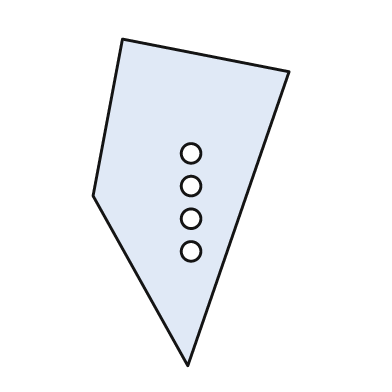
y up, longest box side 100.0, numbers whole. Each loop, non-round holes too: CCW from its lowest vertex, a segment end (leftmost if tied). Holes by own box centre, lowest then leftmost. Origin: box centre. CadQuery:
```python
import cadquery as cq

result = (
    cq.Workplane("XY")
    .moveTo(-1.0, -50.0)
    .lineTo(30.0, 40.0)
    .lineTo(-21.0, 50.0)
    .lineTo(-30.0, 2.0)
    .close()
    .moveTo(0.0, -15.0)
    .circle(3.0)
    .moveTo(0.0, -5.0)
    .circle(3.0)
    .moveTo(0.0, 5.0)
    .circle(3.0)
    .moveTo(0.0, 15.0)
    .circle(3.0)
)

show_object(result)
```